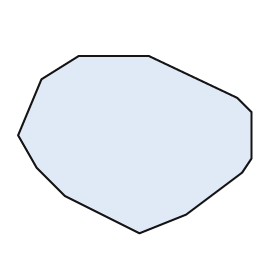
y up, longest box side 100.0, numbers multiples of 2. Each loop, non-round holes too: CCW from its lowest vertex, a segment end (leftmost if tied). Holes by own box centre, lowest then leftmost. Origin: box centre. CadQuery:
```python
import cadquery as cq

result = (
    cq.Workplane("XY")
    .moveTo(2.0, -38.0)
    .lineTo(22.0, -30.0)
    .lineTo(46.0, -12.0)
    .lineTo(50.0, -6.0)
    .lineTo(50.0, 14.0)
    .lineTo(44.0, 20.0)
    .lineTo(6.0, 38.0)
    .lineTo(-24.0, 38.0)
    .lineTo(-40.0, 28.0)
    .lineTo(-50.0, 4.0)
    .lineTo(-42.0, -10.0)
    .lineTo(-30.0, -22.0)
    .close()
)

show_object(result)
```